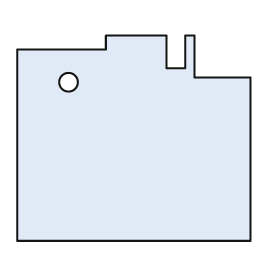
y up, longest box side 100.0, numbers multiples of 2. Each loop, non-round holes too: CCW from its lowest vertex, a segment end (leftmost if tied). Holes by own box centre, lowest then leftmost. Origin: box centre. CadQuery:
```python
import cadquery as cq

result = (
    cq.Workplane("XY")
    .moveTo(-50.0, -44.0)
    .lineTo(50.0, -44.0)
    .lineTo(50.0, 26.0)
    .lineTo(26.0, 26.0)
    .lineTo(26.0, 44.0)
    .lineTo(22.0, 44.0)
    .lineTo(22.0, 30.0)
    .lineTo(14.0, 30.0)
    .lineTo(14.0, 44.0)
    .lineTo(-12.0, 44.0)
    .lineTo(-12.0, 38.0)
    .lineTo(-50.0, 38.0)
    .close()
    .moveTo(-28.0, 24.0)
    .circle(4.0)
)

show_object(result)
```